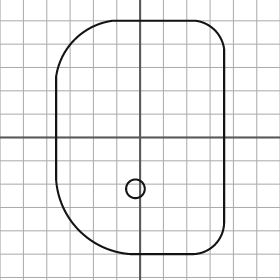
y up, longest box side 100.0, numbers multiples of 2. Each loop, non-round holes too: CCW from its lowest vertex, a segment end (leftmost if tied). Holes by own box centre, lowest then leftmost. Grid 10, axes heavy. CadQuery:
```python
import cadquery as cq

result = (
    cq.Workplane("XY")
    .moveTo(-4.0, -50.0)
    .lineTo(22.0, -50.0)
    .threePointArc((32.0, -46.0), (36.0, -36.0))
    .lineTo(36.0, 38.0)
    .threePointArc((32.0, 46.0), (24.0, 50.0))
    .lineTo(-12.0, 50.0)
    .threePointArc((-28.0, 42.0), (-36.0, 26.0))
    .lineTo(-36.0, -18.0)
    .threePointArc((-26.0, -40.0), (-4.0, -50.0))
    .close()
    .moveTo(-2.0, -22.0)
    .circle(4.0)
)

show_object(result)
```